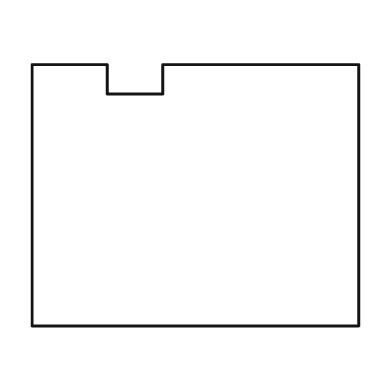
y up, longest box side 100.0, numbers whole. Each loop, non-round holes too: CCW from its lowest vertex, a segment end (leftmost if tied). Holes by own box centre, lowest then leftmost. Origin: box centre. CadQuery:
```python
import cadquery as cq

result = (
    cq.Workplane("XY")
    .moveTo(-50.0, -40.0)
    .lineTo(50.0, -40.0)
    .lineTo(50.0, 40.0)
    .lineTo(-10.0, 40.0)
    .lineTo(-10.0, 31.0)
    .lineTo(-27.0, 31.0)
    .lineTo(-27.0, 40.0)
    .lineTo(-50.0, 40.0)
    .close()
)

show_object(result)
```